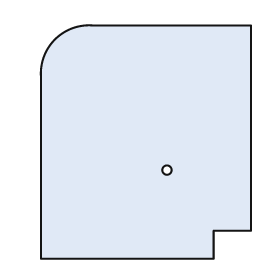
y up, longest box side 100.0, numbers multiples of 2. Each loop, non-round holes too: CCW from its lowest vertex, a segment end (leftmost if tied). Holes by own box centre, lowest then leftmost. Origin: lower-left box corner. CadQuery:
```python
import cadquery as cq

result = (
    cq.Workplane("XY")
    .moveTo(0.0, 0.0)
    .lineTo(74.0, 0.0)
    .lineTo(74.0, 12.0)
    .lineTo(90.0, 12.0)
    .lineTo(90.0, 100.0)
    .lineTo(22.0, 100.0)
    .threePointArc((6.0, 94.0), (0.0, 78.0))
    .close()
    .moveTo(54.0, 38.0)
    .circle(2.0)
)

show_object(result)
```